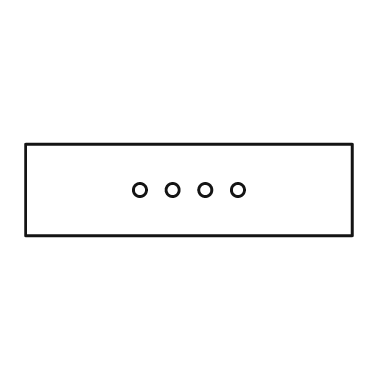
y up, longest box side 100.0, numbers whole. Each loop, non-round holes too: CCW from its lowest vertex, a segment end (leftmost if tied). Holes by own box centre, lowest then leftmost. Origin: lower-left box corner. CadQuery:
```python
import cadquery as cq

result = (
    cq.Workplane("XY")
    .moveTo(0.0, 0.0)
    .lineTo(100.0, 0.0)
    .lineTo(100.0, 28.0)
    .lineTo(0.0, 28.0)
    .close()
    .moveTo(35.0, 14.0)
    .circle(2.0)
    .moveTo(45.0, 14.0)
    .circle(2.0)
    .moveTo(55.0, 14.0)
    .circle(2.0)
    .moveTo(65.0, 14.0)
    .circle(2.0)
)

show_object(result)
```